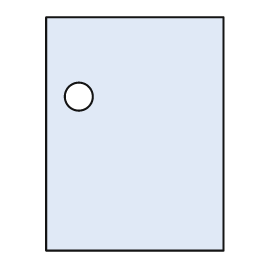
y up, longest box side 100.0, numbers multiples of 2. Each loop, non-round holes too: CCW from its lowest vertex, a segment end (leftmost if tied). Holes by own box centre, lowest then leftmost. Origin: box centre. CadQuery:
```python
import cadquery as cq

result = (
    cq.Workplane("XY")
    .moveTo(-38.0, -50.0)
    .lineTo(38.0, -50.0)
    .lineTo(38.0, 50.0)
    .lineTo(-38.0, 50.0)
    .close()
    .moveTo(-24.0, 16.0)
    .circle(6.0)
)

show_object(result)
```